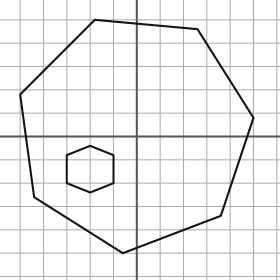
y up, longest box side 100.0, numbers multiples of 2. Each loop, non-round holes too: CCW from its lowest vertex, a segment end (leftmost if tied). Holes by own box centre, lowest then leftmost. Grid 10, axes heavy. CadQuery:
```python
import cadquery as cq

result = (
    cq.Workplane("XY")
    .moveTo(-6.0, -50.0)
    .lineTo(36.0, -34.0)
    .lineTo(50.0, 8.0)
    .lineTo(26.0, 46.0)
    .lineTo(-18.0, 50.0)
    .lineTo(-50.0, 18.0)
    .lineTo(-44.0, -26.0)
    .close()
    .moveTo(-20.0, -24.0)
    .lineTo(-10.0, -20.0)
    .lineTo(-10.0, -8.0)
    .lineTo(-20.0, -4.0)
    .lineTo(-30.0, -8.0)
    .lineTo(-30.0, -20.0)
    .close()
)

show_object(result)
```